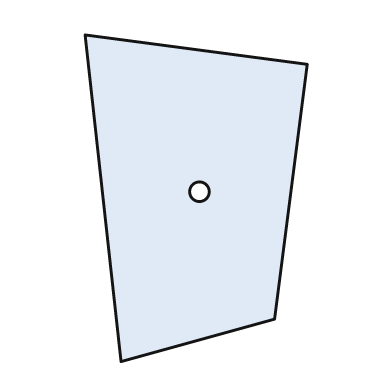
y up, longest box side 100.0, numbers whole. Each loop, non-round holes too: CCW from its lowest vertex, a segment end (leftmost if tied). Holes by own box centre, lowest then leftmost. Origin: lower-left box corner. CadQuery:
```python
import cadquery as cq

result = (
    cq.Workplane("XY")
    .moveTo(11.0, 0.0)
    .lineTo(58.0, 13.0)
    .lineTo(68.0, 91.0)
    .lineTo(0.0, 100.0)
    .close()
    .moveTo(35.0, 52.0)
    .circle(3.0)
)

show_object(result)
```